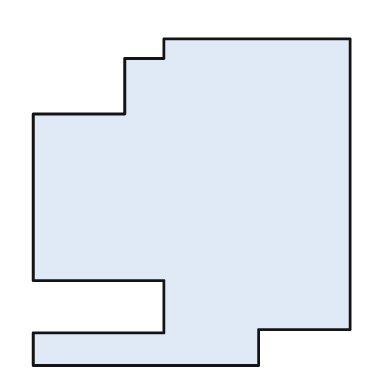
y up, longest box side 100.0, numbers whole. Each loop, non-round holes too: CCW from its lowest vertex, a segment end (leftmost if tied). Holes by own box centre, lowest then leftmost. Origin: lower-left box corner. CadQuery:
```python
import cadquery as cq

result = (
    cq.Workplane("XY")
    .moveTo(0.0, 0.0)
    .lineTo(69.0, 0.0)
    .lineTo(69.0, 11.0)
    .lineTo(97.0, 11.0)
    .lineTo(97.0, 100.0)
    .lineTo(40.0, 100.0)
    .lineTo(40.0, 94.0)
    .lineTo(28.0, 94.0)
    .lineTo(28.0, 77.0)
    .lineTo(0.0, 77.0)
    .lineTo(0.0, 26.0)
    .lineTo(40.0, 26.0)
    .lineTo(40.0, 10.0)
    .lineTo(0.0, 10.0)
    .close()
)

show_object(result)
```